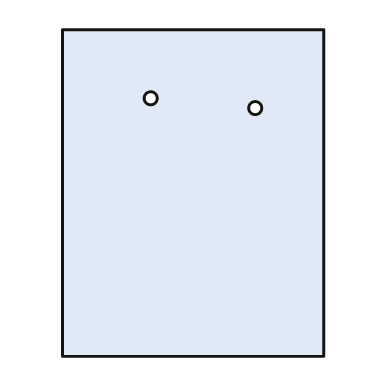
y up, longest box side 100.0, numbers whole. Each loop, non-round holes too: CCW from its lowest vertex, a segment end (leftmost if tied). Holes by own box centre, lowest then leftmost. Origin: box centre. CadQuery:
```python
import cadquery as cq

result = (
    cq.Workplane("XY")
    .moveTo(-40.0, -50.0)
    .lineTo(40.0, -50.0)
    .lineTo(40.0, 50.0)
    .lineTo(-40.0, 50.0)
    .close()
    .moveTo(19.0, 26.0)
    .circle(2.0)
    .moveTo(-13.0, 29.0)
    .circle(2.0)
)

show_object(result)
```